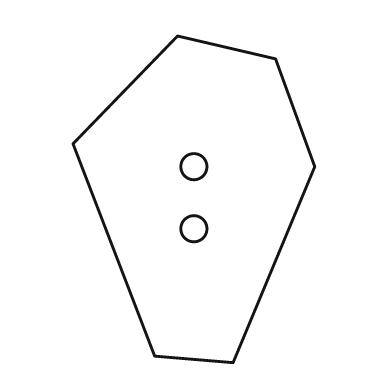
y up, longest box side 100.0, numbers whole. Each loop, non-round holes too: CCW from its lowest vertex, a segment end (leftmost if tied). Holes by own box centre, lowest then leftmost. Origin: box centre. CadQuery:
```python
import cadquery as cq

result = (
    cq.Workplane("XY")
    .moveTo(12.0, -50.0)
    .lineTo(37.0, 10.0)
    .lineTo(25.0, 43.0)
    .lineTo(-5.0, 50.0)
    .lineTo(-37.0, 17.0)
    .lineTo(-12.0, -48.0)
    .close()
    .moveTo(0.0, -9.0)
    .circle(4.0)
    .moveTo(0.0, 10.0)
    .circle(4.0)
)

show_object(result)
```